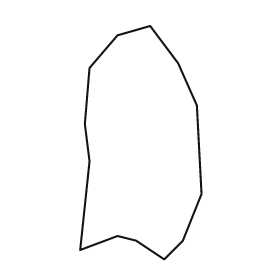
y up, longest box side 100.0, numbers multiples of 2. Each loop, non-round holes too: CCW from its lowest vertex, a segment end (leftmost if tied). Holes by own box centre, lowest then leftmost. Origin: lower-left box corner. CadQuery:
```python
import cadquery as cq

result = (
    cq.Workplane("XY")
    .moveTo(36.0, 0.0)
    .lineTo(44.0, 8.0)
    .lineTo(52.0, 28.0)
    .lineTo(50.0, 66.0)
    .lineTo(42.0, 84.0)
    .lineTo(30.0, 100.0)
    .lineTo(16.0, 96.0)
    .lineTo(4.0, 82.0)
    .lineTo(2.0, 58.0)
    .lineTo(4.0, 42.0)
    .lineTo(0.0, 4.0)
    .lineTo(16.0, 10.0)
    .lineTo(24.0, 8.0)
    .close()
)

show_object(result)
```